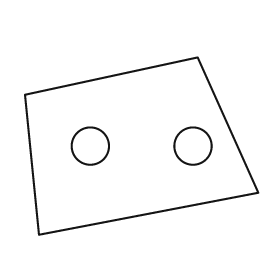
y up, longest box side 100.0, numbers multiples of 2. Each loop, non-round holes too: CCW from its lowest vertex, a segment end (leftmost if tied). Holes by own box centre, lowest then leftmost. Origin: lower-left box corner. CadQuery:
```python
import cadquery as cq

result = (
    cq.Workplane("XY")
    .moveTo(6.0, 0.0)
    .lineTo(100.0, 18.0)
    .lineTo(74.0, 76.0)
    .lineTo(0.0, 60.0)
    .close()
    .moveTo(28.0, 38.0)
    .circle(8.0)
    .moveTo(72.0, 38.0)
    .circle(8.0)
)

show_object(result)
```